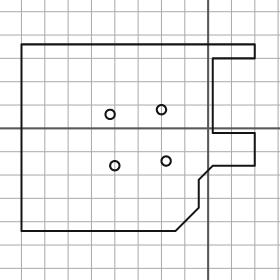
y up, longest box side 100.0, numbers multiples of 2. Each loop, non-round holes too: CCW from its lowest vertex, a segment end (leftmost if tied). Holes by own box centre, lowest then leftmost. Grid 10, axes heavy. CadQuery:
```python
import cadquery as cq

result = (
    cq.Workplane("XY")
    .moveTo(-80.0, -44.0)
    .lineTo(-14.0, -44.0)
    .lineTo(-4.0, -34.0)
    .lineTo(-4.0, -22.0)
    .lineTo(2.0, -16.0)
    .lineTo(20.0, -16.0)
    .lineTo(20.0, -2.0)
    .lineTo(2.0, -2.0)
    .lineTo(2.0, 30.0)
    .lineTo(20.0, 30.0)
    .lineTo(20.0, 36.0)
    .lineTo(-80.0, 36.0)
    .close()
    .moveTo(-40.0, -16.0)
    .circle(2.0)
    .moveTo(-18.0, -14.0)
    .circle(2.0)
    .moveTo(-42.0, 6.0)
    .circle(2.0)
    .moveTo(-20.0, 8.0)
    .circle(2.0)
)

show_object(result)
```